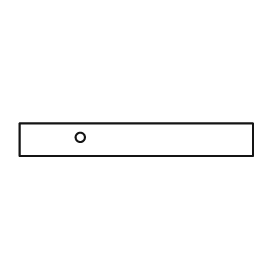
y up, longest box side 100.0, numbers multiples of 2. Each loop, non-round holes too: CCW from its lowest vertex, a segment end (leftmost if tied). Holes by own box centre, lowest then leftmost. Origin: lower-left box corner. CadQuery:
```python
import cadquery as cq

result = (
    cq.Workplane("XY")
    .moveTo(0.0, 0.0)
    .lineTo(100.0, 0.0)
    .lineTo(100.0, 14.0)
    .lineTo(0.0, 14.0)
    .close()
    .moveTo(26.0, 8.0)
    .circle(2.0)
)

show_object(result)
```